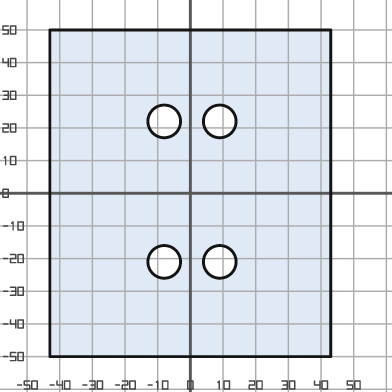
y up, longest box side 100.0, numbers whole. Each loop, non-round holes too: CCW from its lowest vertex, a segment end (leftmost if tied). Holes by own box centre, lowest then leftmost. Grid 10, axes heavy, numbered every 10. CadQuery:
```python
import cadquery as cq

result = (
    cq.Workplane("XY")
    .moveTo(-43.0, -50.0)
    .lineTo(43.0, -50.0)
    .lineTo(43.0, 50.0)
    .lineTo(-43.0, 50.0)
    .close()
    .moveTo(-8.0, -21.0)
    .circle(5.0)
    .moveTo(9.0, -21.0)
    .circle(5.0)
    .moveTo(-8.0, 22.0)
    .circle(5.0)
    .moveTo(9.0, 22.0)
    .circle(5.0)
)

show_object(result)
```